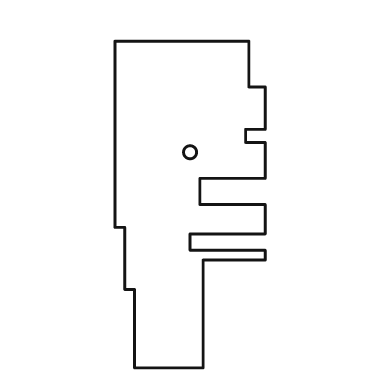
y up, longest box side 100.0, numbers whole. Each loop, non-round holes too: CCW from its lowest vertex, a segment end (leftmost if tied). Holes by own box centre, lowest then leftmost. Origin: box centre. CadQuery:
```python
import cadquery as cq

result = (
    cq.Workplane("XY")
    .moveTo(-17.0, -50.0)
    .lineTo(4.0, -50.0)
    .lineTo(4.0, -17.0)
    .lineTo(23.0, -17.0)
    .lineTo(23.0, -14.0)
    .lineTo(0.0, -14.0)
    .lineTo(0.0, -9.0)
    .lineTo(23.0, -9.0)
    .lineTo(23.0, 0.0)
    .lineTo(3.0, 0.0)
    .lineTo(3.0, 8.0)
    .lineTo(23.0, 8.0)
    .lineTo(23.0, 19.0)
    .lineTo(17.0, 19.0)
    .lineTo(17.0, 23.0)
    .lineTo(23.0, 23.0)
    .lineTo(23.0, 36.0)
    .lineTo(18.0, 36.0)
    .lineTo(18.0, 50.0)
    .lineTo(-23.0, 50.0)
    .lineTo(-23.0, -7.0)
    .lineTo(-20.0, -7.0)
    .lineTo(-20.0, -26.0)
    .lineTo(-17.0, -26.0)
    .close()
    .moveTo(0.0, 16.0)
    .circle(2.0)
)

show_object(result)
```